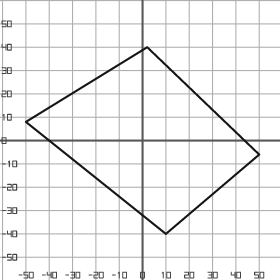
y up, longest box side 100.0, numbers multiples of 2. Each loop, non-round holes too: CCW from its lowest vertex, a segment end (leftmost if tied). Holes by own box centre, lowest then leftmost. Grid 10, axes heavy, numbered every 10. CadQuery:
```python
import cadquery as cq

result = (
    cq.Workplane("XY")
    .moveTo(10.0, -40.0)
    .lineTo(50.0, -6.0)
    .lineTo(2.0, 40.0)
    .lineTo(-50.0, 8.0)
    .close()
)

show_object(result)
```